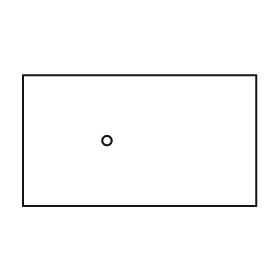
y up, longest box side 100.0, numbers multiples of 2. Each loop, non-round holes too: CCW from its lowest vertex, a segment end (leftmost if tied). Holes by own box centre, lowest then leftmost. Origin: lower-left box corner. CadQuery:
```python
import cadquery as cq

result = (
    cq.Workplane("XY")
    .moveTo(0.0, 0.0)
    .lineTo(100.0, 0.0)
    .lineTo(100.0, 56.0)
    .lineTo(0.0, 56.0)
    .close()
    .moveTo(36.0, 28.0)
    .circle(2.0)
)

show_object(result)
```